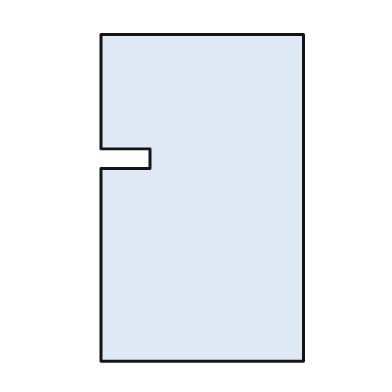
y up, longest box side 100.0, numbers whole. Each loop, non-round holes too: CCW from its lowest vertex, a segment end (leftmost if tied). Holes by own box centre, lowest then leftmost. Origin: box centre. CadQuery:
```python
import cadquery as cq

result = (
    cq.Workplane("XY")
    .moveTo(-31.0, -50.0)
    .lineTo(31.0, -50.0)
    .lineTo(31.0, 50.0)
    .lineTo(-31.0, 50.0)
    .lineTo(-31.0, 15.0)
    .lineTo(-16.0, 15.0)
    .lineTo(-16.0, 9.0)
    .lineTo(-31.0, 9.0)
    .close()
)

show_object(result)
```